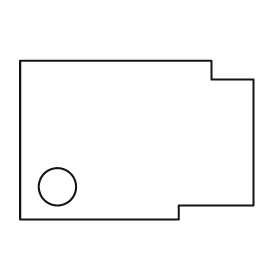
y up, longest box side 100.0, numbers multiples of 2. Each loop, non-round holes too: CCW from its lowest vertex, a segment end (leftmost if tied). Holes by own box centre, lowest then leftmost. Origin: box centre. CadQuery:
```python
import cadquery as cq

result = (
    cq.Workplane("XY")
    .moveTo(-50.0, -34.0)
    .lineTo(18.0, -34.0)
    .lineTo(18.0, -28.0)
    .lineTo(50.0, -28.0)
    .lineTo(50.0, 26.0)
    .lineTo(32.0, 26.0)
    .lineTo(32.0, 34.0)
    .lineTo(-50.0, 34.0)
    .close()
    .moveTo(-34.0, -20.0)
    .circle(8.0)
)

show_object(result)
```